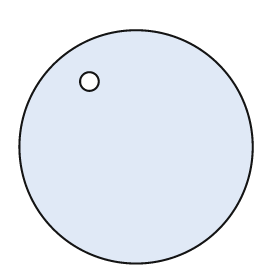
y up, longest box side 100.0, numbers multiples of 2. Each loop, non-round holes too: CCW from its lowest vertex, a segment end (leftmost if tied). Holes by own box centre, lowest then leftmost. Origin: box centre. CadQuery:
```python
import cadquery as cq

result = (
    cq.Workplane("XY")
    .moveTo(0.0, 0.0)
    .circle(50.0)
    .moveTo(-20.0, 28.0)
    .circle(4.0)
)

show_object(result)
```